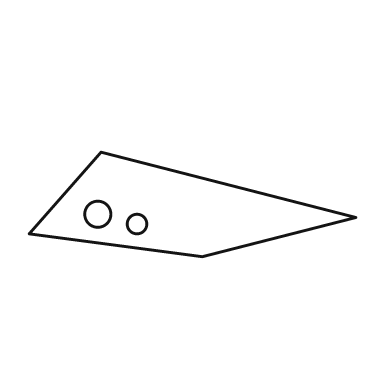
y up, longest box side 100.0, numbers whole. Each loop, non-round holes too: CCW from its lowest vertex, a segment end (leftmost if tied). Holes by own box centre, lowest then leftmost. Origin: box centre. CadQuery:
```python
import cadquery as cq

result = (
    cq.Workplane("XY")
    .moveTo(3.0, -16.0)
    .lineTo(50.0, -4.0)
    .lineTo(-28.0, 16.0)
    .lineTo(-50.0, -9.0)
    .close()
    .moveTo(-17.0, -6.0)
    .circle(3.0)
    .moveTo(-29.0, -3.0)
    .circle(4.0)
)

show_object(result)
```